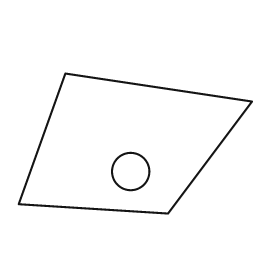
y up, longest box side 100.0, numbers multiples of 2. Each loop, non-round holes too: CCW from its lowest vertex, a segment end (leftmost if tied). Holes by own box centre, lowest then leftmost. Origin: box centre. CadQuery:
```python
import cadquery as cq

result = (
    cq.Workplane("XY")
    .moveTo(14.0, -30.0)
    .lineTo(50.0, 18.0)
    .lineTo(-30.0, 30.0)
    .lineTo(-50.0, -26.0)
    .close()
    .moveTo(-2.0, -12.0)
    .circle(8.0)
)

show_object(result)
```